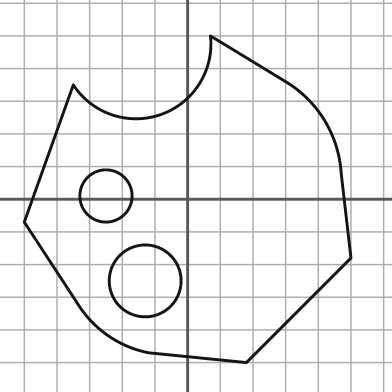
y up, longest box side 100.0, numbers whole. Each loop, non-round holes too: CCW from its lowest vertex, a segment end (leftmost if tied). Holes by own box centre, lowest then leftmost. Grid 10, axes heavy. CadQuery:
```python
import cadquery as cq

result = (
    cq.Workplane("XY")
    .moveTo(18.0, -50.0)
    .lineTo(50.0, -18.0)
    .lineTo(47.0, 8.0)
    .threePointArc((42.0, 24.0), (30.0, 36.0))
    .lineTo(7.0, 50.0)
    .threePointArc((-8.0, 26.0), (-35.0, 35.0))
    .lineTo(-50.0, -7.0)
    .lineTo(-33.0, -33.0)
    .threePointArc((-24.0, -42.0), (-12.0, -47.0))
    .close()
    .moveTo(-13.0, -25.0)
    .circle(11.0)
    .moveTo(-25.0, 1.0)
    .circle(8.0)
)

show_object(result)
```